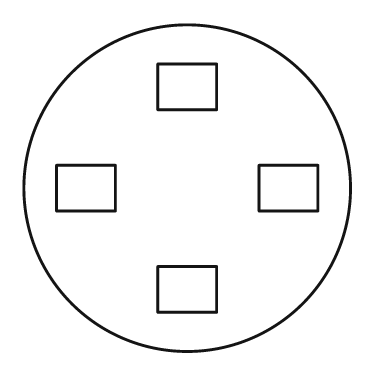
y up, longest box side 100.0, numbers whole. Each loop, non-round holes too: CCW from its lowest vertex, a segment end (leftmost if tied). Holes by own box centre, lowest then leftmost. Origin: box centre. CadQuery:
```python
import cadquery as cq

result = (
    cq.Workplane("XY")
    .moveTo(0.0, 0.0)
    .circle(50.0)
    .moveTo(-9.0, -38.0)
    .lineTo(9.0, -38.0)
    .lineTo(9.0, -24.0)
    .lineTo(-9.0, -24.0)
    .close()
    .moveTo(-40.0, -7.0)
    .lineTo(-22.0, -7.0)
    .lineTo(-22.0, 7.0)
    .lineTo(-40.0, 7.0)
    .close()
    .moveTo(22.0, -7.0)
    .lineTo(40.0, -7.0)
    .lineTo(40.0, 7.0)
    .lineTo(22.0, 7.0)
    .close()
    .moveTo(-9.0, 24.0)
    .lineTo(9.0, 24.0)
    .lineTo(9.0, 38.0)
    .lineTo(-9.0, 38.0)
    .close()
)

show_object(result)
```